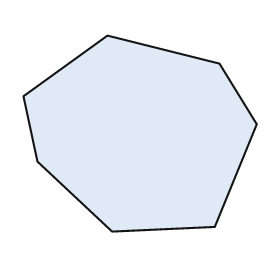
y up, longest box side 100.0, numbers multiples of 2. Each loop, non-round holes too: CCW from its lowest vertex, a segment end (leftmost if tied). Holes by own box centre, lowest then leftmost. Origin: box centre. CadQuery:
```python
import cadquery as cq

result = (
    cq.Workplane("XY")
    .moveTo(-12.0, -42.0)
    .lineTo(32.0, -40.0)
    .lineTo(50.0, 4.0)
    .lineTo(34.0, 30.0)
    .lineTo(-14.0, 42.0)
    .lineTo(-50.0, 16.0)
    .lineTo(-44.0, -12.0)
    .close()
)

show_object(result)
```